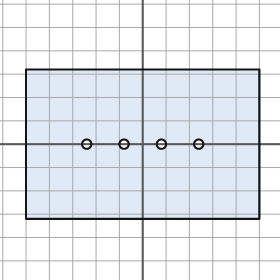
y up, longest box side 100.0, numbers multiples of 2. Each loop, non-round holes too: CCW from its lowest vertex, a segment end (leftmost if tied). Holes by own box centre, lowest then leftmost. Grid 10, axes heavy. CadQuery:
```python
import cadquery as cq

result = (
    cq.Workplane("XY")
    .moveTo(-50.0, -32.0)
    .lineTo(50.0, -32.0)
    .lineTo(50.0, 32.0)
    .lineTo(-50.0, 32.0)
    .close()
    .moveTo(-24.0, 0.0)
    .circle(2.0)
    .moveTo(-8.0, 0.0)
    .circle(2.0)
    .moveTo(8.0, 0.0)
    .circle(2.0)
    .moveTo(24.0, 0.0)
    .circle(2.0)
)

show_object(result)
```